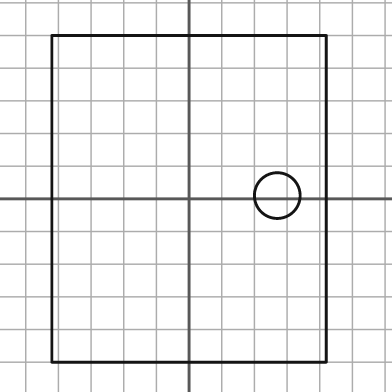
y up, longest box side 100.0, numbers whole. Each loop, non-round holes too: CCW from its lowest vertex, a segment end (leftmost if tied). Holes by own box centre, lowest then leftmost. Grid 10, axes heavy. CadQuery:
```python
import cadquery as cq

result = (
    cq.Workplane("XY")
    .moveTo(-42.0, -50.0)
    .lineTo(42.0, -50.0)
    .lineTo(42.0, 50.0)
    .lineTo(-42.0, 50.0)
    .close()
    .moveTo(27.0, 1.0)
    .circle(7.0)
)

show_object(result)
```